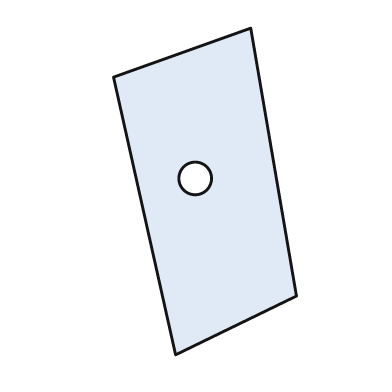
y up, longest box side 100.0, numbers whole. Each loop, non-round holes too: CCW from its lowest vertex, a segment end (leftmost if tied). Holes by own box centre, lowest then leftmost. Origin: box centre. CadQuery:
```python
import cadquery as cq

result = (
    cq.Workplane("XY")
    .moveTo(-9.0, -50.0)
    .lineTo(28.0, -32.0)
    .lineTo(14.0, 50.0)
    .lineTo(-28.0, 35.0)
    .close()
    .moveTo(-3.0, 4.0)
    .circle(5.0)
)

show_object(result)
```